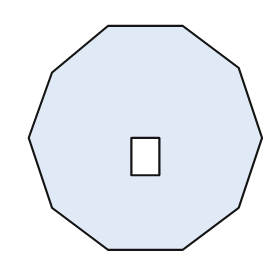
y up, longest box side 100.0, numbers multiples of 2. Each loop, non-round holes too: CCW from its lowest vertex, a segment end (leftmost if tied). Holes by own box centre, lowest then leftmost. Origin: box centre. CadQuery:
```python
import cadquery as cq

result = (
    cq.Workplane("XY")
    .moveTo(-16.0, -48.0)
    .lineTo(16.0, -48.0)
    .lineTo(40.0, -30.0)
    .lineTo(50.0, 0.0)
    .lineTo(40.0, 30.0)
    .lineTo(16.0, 48.0)
    .lineTo(-16.0, 48.0)
    .lineTo(-40.0, 28.0)
    .lineTo(-50.0, 0.0)
    .lineTo(-40.0, -30.0)
    .close()
    .moveTo(-6.0, -16.0)
    .lineTo(6.0, -16.0)
    .lineTo(6.0, 0.0)
    .lineTo(-6.0, 0.0)
    .close()
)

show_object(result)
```